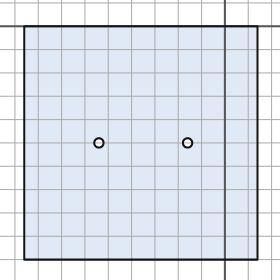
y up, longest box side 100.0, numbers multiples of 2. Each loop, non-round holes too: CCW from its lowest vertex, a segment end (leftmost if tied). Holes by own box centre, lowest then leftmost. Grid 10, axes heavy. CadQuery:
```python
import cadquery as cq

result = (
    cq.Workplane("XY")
    .moveTo(-86.0, -100.0)
    .lineTo(14.0, -100.0)
    .lineTo(14.0, 0.0)
    .lineTo(-86.0, 0.0)
    .close()
    .moveTo(-54.0, -50.0)
    .circle(2.0)
    .moveTo(-16.0, -50.0)
    .circle(2.0)
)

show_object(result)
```